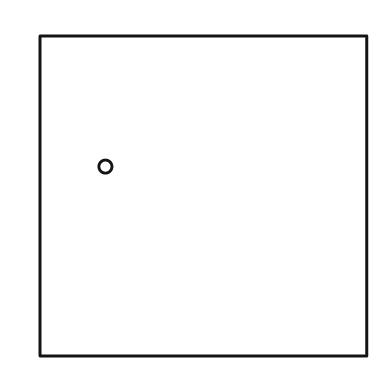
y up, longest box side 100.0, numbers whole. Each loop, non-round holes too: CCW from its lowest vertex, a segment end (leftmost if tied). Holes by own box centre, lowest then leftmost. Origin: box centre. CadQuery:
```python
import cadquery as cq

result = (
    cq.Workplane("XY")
    .moveTo(-50.0, -49.0)
    .lineTo(50.0, -49.0)
    .lineTo(50.0, 49.0)
    .lineTo(-50.0, 49.0)
    .close()
    .moveTo(-30.0, 9.0)
    .circle(2.0)
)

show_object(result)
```